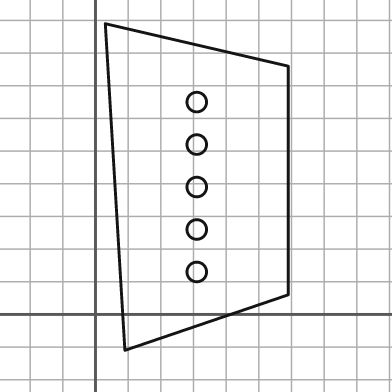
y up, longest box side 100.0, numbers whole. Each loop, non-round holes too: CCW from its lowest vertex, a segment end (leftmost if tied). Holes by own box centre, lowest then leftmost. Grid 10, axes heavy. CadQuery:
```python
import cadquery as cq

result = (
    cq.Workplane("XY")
    .moveTo(9.0, -11.0)
    .lineTo(59.0, 6.0)
    .lineTo(59.0, 76.0)
    .lineTo(3.0, 89.0)
    .close()
    .moveTo(31.0, 13.0)
    .circle(3.0)
    .moveTo(31.0, 26.0)
    .circle(3.0)
    .moveTo(31.0, 39.0)
    .circle(3.0)
    .moveTo(31.0, 52.0)
    .circle(3.0)
    .moveTo(31.0, 65.0)
    .circle(3.0)
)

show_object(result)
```